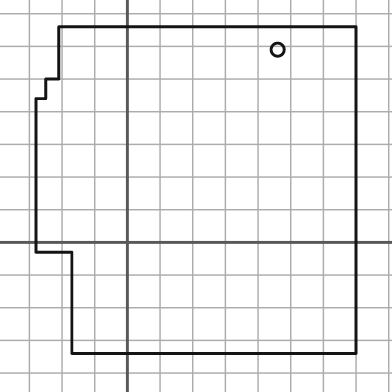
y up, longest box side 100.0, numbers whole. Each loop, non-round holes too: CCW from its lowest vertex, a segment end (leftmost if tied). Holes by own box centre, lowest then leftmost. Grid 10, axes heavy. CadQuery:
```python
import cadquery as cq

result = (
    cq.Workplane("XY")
    .moveTo(-17.0, -34.0)
    .lineTo(70.0, -34.0)
    .lineTo(70.0, 66.0)
    .lineTo(-21.0, 66.0)
    .lineTo(-21.0, 50.0)
    .lineTo(-25.0, 50.0)
    .lineTo(-25.0, 44.0)
    .lineTo(-28.0, 44.0)
    .lineTo(-28.0, -3.0)
    .lineTo(-17.0, -3.0)
    .close()
    .moveTo(46.0, 59.0)
    .circle(2.0)
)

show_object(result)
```